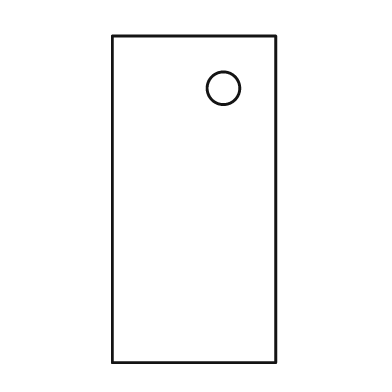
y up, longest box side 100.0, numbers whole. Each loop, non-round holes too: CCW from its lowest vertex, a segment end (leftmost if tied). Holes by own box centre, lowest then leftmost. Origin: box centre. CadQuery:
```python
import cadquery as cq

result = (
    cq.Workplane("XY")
    .moveTo(-25.0, -50.0)
    .lineTo(25.0, -50.0)
    .lineTo(25.0, 50.0)
    .lineTo(-25.0, 50.0)
    .close()
    .moveTo(9.0, 34.0)
    .circle(5.0)
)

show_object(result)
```